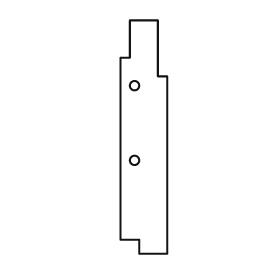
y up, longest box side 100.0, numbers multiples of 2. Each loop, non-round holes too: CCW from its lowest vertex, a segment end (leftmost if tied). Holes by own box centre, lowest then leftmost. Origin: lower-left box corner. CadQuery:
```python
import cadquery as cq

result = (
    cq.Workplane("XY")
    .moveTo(8.0, 0.0)
    .lineTo(20.0, 0.0)
    .lineTo(20.0, 76.0)
    .lineTo(16.0, 76.0)
    .lineTo(16.0, 100.0)
    .lineTo(4.0, 100.0)
    .lineTo(4.0, 84.0)
    .lineTo(0.0, 84.0)
    .lineTo(0.0, 6.0)
    .lineTo(8.0, 6.0)
    .close()
    .moveTo(6.0, 40.0)
    .circle(2.0)
    .moveTo(6.0, 72.0)
    .circle(2.0)
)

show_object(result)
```